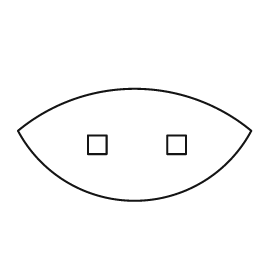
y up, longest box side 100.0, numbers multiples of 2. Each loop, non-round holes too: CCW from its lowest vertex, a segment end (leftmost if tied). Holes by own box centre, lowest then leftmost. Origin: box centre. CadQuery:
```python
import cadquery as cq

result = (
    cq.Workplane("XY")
    .moveTo(-50.0, 6.0)
    .threePointArc((0.0, -24.0), (50.0, 6.0))
    .threePointArc((0.0, 24.0), (-50.0, 6.0))
    .close()
    .moveTo(-20.0, -4.0)
    .lineTo(-12.0, -4.0)
    .lineTo(-12.0, 4.0)
    .lineTo(-20.0, 4.0)
    .close()
    .moveTo(14.0, -4.0)
    .lineTo(22.0, -4.0)
    .lineTo(22.0, 4.0)
    .lineTo(14.0, 4.0)
    .close()
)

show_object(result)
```